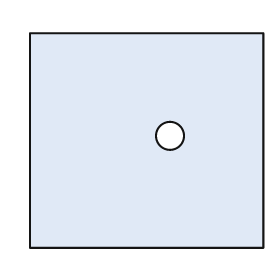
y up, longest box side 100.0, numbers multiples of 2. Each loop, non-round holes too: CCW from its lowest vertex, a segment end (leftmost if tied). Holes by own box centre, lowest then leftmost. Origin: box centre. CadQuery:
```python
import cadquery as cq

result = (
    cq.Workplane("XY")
    .moveTo(-50.0, -46.0)
    .lineTo(50.0, -46.0)
    .lineTo(50.0, 46.0)
    .lineTo(-50.0, 46.0)
    .close()
    .moveTo(10.0, 2.0)
    .circle(6.0)
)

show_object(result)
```